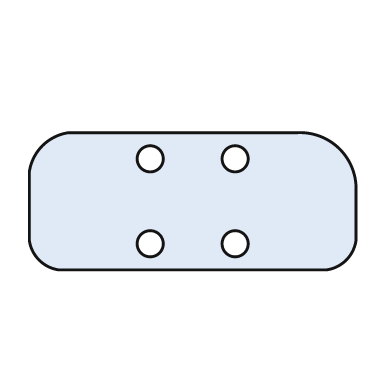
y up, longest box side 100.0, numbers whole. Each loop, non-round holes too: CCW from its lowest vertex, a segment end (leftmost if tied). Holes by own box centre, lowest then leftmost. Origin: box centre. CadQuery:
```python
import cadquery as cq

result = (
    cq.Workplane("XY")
    .moveTo(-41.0, -21.0)
    .lineTo(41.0, -21.0)
    .threePointArc((47.0, -18.0), (50.0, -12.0))
    .lineTo(50.0, 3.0)
    .threePointArc((45.0, 16.0), (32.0, 21.0))
    .lineTo(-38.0, 21.0)
    .threePointArc((-46.0, 17.0), (-50.0, 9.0))
    .lineTo(-50.0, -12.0)
    .threePointArc((-47.0, -18.0), (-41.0, -21.0))
    .close()
    .moveTo(-13.0, -13.0)
    .circle(4.0)
    .moveTo(13.0, -13.0)
    .circle(4.0)
    .moveTo(-13.0, 13.0)
    .circle(4.0)
    .moveTo(13.0, 13.0)
    .circle(4.0)
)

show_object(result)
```